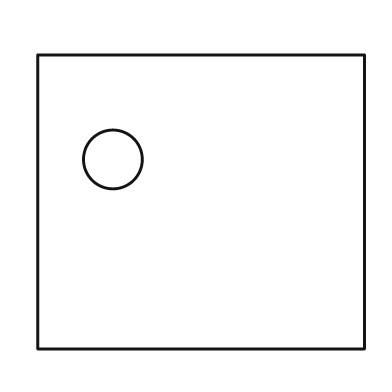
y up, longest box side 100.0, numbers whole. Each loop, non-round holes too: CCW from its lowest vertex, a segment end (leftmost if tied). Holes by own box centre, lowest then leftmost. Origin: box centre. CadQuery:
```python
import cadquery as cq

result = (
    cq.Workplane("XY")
    .moveTo(-50.0, -45.0)
    .lineTo(50.0, -45.0)
    .lineTo(50.0, 45.0)
    .lineTo(-50.0, 45.0)
    .close()
    .moveTo(-27.0, 13.0)
    .circle(9.0)
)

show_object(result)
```